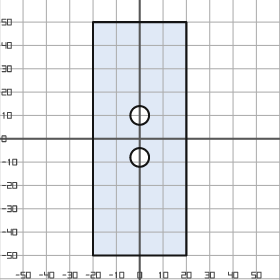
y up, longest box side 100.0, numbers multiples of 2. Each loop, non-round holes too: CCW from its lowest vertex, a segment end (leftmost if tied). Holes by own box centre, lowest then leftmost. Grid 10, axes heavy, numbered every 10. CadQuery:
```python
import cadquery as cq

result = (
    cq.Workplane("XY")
    .moveTo(-20.0, -50.0)
    .lineTo(20.0, -50.0)
    .lineTo(20.0, 50.0)
    .lineTo(-20.0, 50.0)
    .close()
    .moveTo(0.0, -8.0)
    .circle(4.0)
    .moveTo(0.0, 10.0)
    .circle(4.0)
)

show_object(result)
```